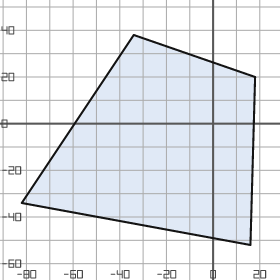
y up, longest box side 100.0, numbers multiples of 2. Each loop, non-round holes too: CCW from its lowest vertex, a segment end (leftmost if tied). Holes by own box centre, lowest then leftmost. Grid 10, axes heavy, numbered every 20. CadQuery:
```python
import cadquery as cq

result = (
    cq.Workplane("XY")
    .moveTo(16.0, -52.0)
    .lineTo(18.0, 20.0)
    .lineTo(-34.0, 38.0)
    .lineTo(-82.0, -34.0)
    .close()
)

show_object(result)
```